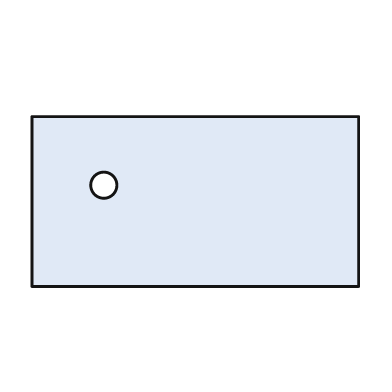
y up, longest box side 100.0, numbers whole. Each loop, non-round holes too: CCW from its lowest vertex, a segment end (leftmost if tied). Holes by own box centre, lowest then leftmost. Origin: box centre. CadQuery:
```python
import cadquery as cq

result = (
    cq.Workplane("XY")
    .moveTo(-50.0, -26.0)
    .lineTo(50.0, -26.0)
    .lineTo(50.0, 26.0)
    .lineTo(-50.0, 26.0)
    .close()
    .moveTo(-28.0, 5.0)
    .circle(4.0)
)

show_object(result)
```